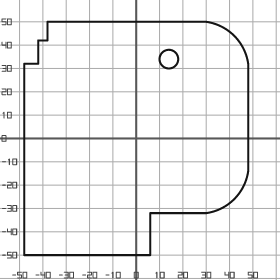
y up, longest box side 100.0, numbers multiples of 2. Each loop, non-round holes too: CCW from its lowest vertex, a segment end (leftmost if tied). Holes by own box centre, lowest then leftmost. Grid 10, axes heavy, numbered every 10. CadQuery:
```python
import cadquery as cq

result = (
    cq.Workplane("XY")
    .moveTo(-48.0, -50.0)
    .lineTo(6.0, -50.0)
    .lineTo(6.0, -32.0)
    .lineTo(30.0, -32.0)
    .threePointArc((42.0, -26.0), (48.0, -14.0))
    .lineTo(48.0, 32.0)
    .threePointArc((42.0, 44.0), (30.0, 50.0))
    .lineTo(-38.0, 50.0)
    .lineTo(-38.0, 42.0)
    .lineTo(-42.0, 42.0)
    .lineTo(-42.0, 32.0)
    .lineTo(-48.0, 32.0)
    .close()
    .moveTo(14.0, 34.0)
    .circle(4.0)
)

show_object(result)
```